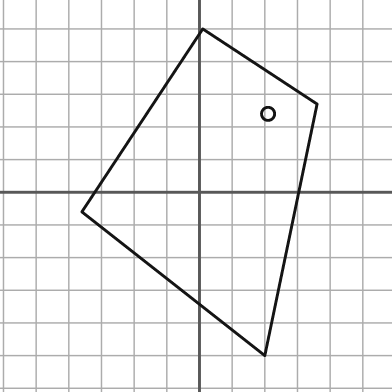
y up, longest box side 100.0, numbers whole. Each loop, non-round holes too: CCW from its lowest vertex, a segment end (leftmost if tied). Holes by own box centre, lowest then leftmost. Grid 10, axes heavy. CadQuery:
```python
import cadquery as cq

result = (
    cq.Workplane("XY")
    .moveTo(20.0, -50.0)
    .lineTo(36.0, 27.0)
    .lineTo(1.0, 50.0)
    .lineTo(-36.0, -6.0)
    .close()
    .moveTo(21.0, 24.0)
    .circle(2.0)
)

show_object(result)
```